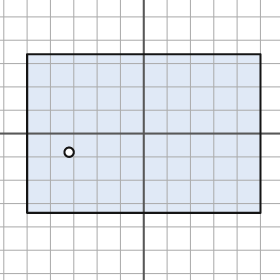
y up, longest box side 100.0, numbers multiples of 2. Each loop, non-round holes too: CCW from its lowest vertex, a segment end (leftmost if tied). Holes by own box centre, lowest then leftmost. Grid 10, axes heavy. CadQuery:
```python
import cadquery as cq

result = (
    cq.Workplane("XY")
    .moveTo(-50.0, -34.0)
    .lineTo(50.0, -34.0)
    .lineTo(50.0, 34.0)
    .lineTo(-50.0, 34.0)
    .close()
    .moveTo(-32.0, -8.0)
    .circle(2.0)
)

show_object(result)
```